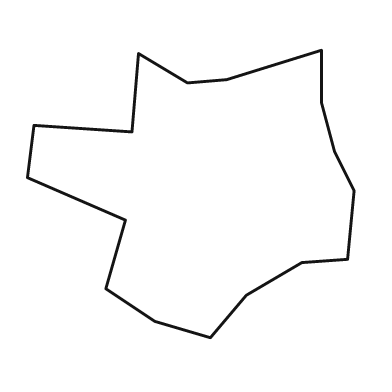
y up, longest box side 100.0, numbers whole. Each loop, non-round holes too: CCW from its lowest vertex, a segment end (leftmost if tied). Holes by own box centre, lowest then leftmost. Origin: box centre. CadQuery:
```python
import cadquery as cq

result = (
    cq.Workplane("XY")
    .moveTo(6.0, -44.0)
    .lineTo(17.0, -31.0)
    .lineTo(34.0, -21.0)
    .lineTo(48.0, -20.0)
    .lineTo(50.0, 1.0)
    .lineTo(44.0, 13.0)
    .lineTo(40.0, 28.0)
    .lineTo(40.0, 44.0)
    .lineTo(11.0, 35.0)
    .lineTo(-1.0, 34.0)
    .lineTo(-16.0, 43.0)
    .lineTo(-18.0, 19.0)
    .lineTo(-48.0, 21.0)
    .lineTo(-50.0, 5.0)
    .lineTo(-20.0, -8.0)
    .lineTo(-26.0, -29.0)
    .lineTo(-11.0, -39.0)
    .close()
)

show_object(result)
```